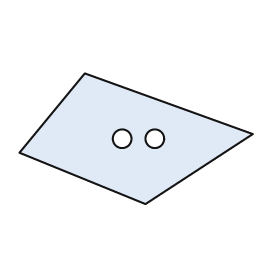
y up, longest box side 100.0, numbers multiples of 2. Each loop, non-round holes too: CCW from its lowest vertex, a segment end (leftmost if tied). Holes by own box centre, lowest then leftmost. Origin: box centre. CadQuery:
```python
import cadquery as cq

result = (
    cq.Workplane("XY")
    .moveTo(4.0, -28.0)
    .lineTo(50.0, 2.0)
    .lineTo(-22.0, 28.0)
    .lineTo(-50.0, -6.0)
    .close()
    .moveTo(-6.0, 0.0)
    .circle(4.0)
    .moveTo(8.0, 0.0)
    .circle(4.0)
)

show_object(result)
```